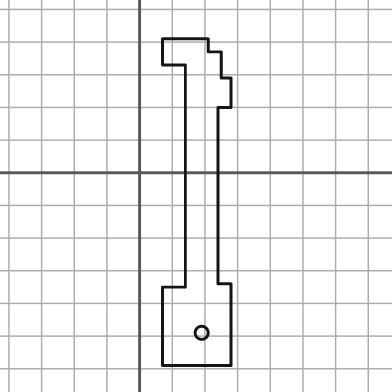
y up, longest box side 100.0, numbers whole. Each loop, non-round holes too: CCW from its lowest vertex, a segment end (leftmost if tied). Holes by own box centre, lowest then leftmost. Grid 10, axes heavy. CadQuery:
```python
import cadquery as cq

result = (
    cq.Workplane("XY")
    .moveTo(7.0, -59.0)
    .lineTo(28.0, -59.0)
    .lineTo(28.0, -34.0)
    .lineTo(24.0, -34.0)
    .lineTo(24.0, 20.0)
    .lineTo(28.0, 20.0)
    .lineTo(28.0, 29.0)
    .lineTo(25.0, 29.0)
    .lineTo(25.0, 37.0)
    .lineTo(21.0, 37.0)
    .lineTo(21.0, 41.0)
    .lineTo(7.0, 41.0)
    .lineTo(7.0, 33.0)
    .lineTo(14.0, 33.0)
    .lineTo(14.0, -35.0)
    .lineTo(7.0, -35.0)
    .close()
    .moveTo(19.0, -49.0)
    .circle(2.0)
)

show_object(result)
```